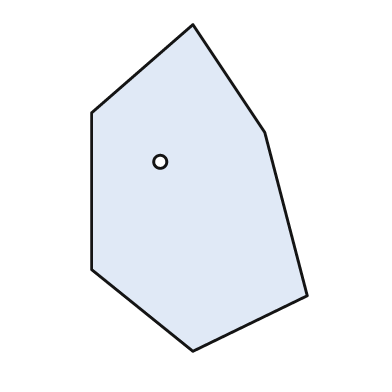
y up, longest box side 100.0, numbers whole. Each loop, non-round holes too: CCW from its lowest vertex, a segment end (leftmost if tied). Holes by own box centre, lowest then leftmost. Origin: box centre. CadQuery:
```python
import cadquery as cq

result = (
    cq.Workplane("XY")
    .moveTo(-2.0, -50.0)
    .lineTo(33.0, -33.0)
    .lineTo(20.0, 17.0)
    .lineTo(-2.0, 50.0)
    .lineTo(-33.0, 23.0)
    .lineTo(-33.0, -25.0)
    .close()
    .moveTo(-12.0, 8.0)
    .circle(2.0)
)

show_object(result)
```